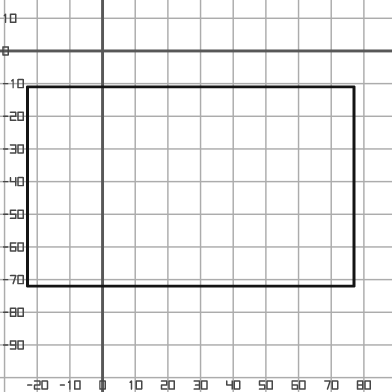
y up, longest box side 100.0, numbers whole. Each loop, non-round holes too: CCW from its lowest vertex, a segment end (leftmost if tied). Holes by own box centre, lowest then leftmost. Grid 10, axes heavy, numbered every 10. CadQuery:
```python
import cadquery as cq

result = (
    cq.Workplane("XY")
    .moveTo(-23.0, -72.0)
    .lineTo(77.0, -72.0)
    .lineTo(77.0, -11.0)
    .lineTo(-23.0, -11.0)
    .close()
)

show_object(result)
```